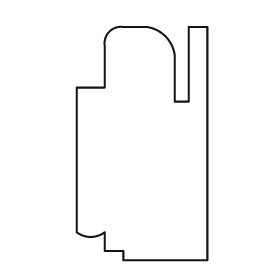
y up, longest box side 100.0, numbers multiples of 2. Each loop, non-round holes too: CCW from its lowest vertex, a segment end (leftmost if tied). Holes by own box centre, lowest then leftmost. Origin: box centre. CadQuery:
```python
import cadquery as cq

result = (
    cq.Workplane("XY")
    .moveTo(-8.0, -50.0)
    .lineTo(28.0, -50.0)
    .lineTo(28.0, 50.0)
    .lineTo(20.0, 50.0)
    .lineTo(20.0, 18.0)
    .lineTo(14.0, 18.0)
    .lineTo(14.0, 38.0)
    .threePointArc((10.0, 46.0), (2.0, 50.0))
    .lineTo(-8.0, 50.0)
    .threePointArc((-14.0, 48.0), (-16.0, 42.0))
    .lineTo(-16.0, 24.0)
    .lineTo(-28.0, 24.0)
    .lineTo(-28.0, -38.0)
    .threePointArc((-22.0, -40.0), (-16.0, -38.0))
    .lineTo(-16.0, -46.0)
    .lineTo(-8.0, -46.0)
    .close()
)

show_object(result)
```